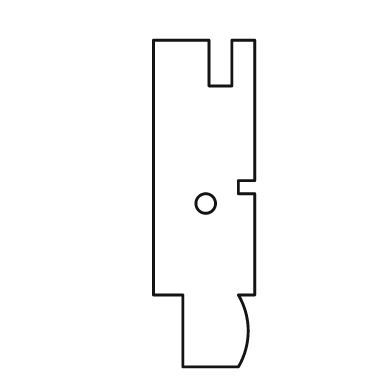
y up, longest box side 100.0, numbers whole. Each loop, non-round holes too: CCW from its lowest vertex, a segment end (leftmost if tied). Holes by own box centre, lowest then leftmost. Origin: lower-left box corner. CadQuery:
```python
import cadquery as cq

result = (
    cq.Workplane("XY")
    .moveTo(9.0, 0.0)
    .lineTo(26.0, 0.0)
    .threePointArc((29.0, 11.0), (26.0, 22.0))
    .lineTo(31.0, 22.0)
    .lineTo(31.0, 53.0)
    .lineTo(26.0, 53.0)
    .lineTo(26.0, 57.0)
    .lineTo(31.0, 57.0)
    .lineTo(31.0, 100.0)
    .lineTo(24.0, 100.0)
    .lineTo(24.0, 86.0)
    .lineTo(17.0, 86.0)
    .lineTo(17.0, 100.0)
    .lineTo(0.0, 100.0)
    .lineTo(0.0, 22.0)
    .lineTo(9.0, 22.0)
    .close()
    .moveTo(16.0, 50.0)
    .circle(3.0)
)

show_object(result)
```